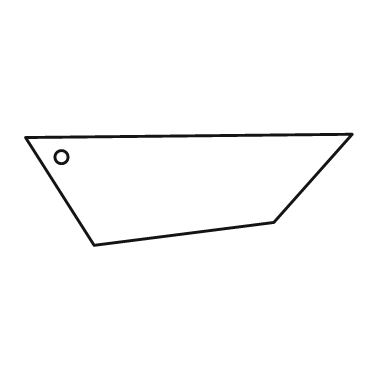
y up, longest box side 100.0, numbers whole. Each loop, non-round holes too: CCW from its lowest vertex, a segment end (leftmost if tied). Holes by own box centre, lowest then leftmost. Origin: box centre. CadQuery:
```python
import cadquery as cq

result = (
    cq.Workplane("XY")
    .moveTo(-29.0, -17.0)
    .lineTo(26.0, -10.0)
    .lineTo(50.0, 17.0)
    .lineTo(-50.0, 16.0)
    .close()
    .moveTo(-39.0, 10.0)
    .circle(2.0)
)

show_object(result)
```